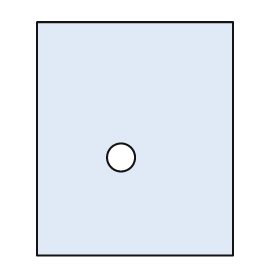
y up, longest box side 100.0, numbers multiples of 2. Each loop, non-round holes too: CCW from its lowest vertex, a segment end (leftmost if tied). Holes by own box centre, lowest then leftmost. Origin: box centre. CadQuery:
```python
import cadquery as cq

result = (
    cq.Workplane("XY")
    .moveTo(-42.0, -50.0)
    .lineTo(42.0, -50.0)
    .lineTo(42.0, 50.0)
    .lineTo(-42.0, 50.0)
    .close()
    .moveTo(-6.0, -8.0)
    .circle(6.0)
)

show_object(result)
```